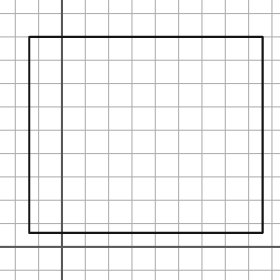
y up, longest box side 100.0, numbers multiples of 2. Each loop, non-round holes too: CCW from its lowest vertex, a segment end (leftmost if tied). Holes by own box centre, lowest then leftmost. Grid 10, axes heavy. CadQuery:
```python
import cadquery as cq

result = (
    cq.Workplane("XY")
    .moveTo(-14.0, 6.0)
    .lineTo(86.0, 6.0)
    .lineTo(86.0, 90.0)
    .lineTo(-14.0, 90.0)
    .close()
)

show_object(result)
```